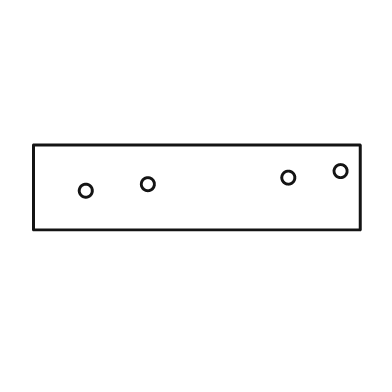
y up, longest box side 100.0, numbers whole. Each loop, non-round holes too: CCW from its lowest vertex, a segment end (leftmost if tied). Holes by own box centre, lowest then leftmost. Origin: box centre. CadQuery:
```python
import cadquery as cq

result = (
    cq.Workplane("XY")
    .moveTo(-50.0, -13.0)
    .lineTo(50.0, -13.0)
    .lineTo(50.0, 13.0)
    .lineTo(-50.0, 13.0)
    .close()
    .moveTo(-34.0, -1.0)
    .circle(2.0)
    .moveTo(-15.0, 1.0)
    .circle(2.0)
    .moveTo(28.0, 3.0)
    .circle(2.0)
    .moveTo(44.0, 5.0)
    .circle(2.0)
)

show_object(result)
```